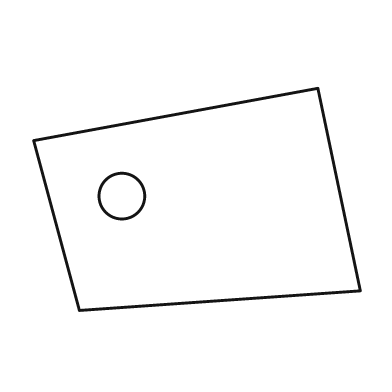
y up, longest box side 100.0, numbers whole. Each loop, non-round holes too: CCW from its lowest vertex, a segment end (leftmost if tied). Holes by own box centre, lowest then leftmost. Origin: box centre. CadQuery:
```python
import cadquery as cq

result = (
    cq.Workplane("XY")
    .moveTo(-36.0, -34.0)
    .lineTo(50.0, -28.0)
    .lineTo(37.0, 34.0)
    .lineTo(-50.0, 18.0)
    .close()
    .moveTo(-23.0, 1.0)
    .circle(7.0)
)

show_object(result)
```